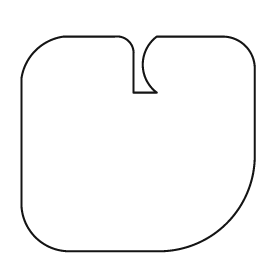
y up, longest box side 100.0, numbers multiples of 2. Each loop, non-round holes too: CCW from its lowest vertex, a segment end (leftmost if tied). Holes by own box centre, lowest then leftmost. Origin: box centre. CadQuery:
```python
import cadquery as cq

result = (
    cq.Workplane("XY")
    .moveTo(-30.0, -46.0)
    .lineTo(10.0, -46.0)
    .threePointArc((38.0, -34.0), (50.0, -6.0))
    .lineTo(50.0, 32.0)
    .threePointArc((46.0, 42.0), (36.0, 46.0))
    .lineTo(8.0, 46.0)
    .threePointArc((2.0, 34.0), (8.0, 22.0))
    .lineTo(-2.0, 22.0)
    .lineTo(-2.0, 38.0)
    .threePointArc((-4.0, 44.0), (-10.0, 46.0))
    .lineTo(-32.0, 46.0)
    .threePointArc((-44.0, 40.0), (-50.0, 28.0))
    .lineTo(-50.0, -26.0)
    .threePointArc((-44.0, -40.0), (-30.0, -46.0))
    .close()
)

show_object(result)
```